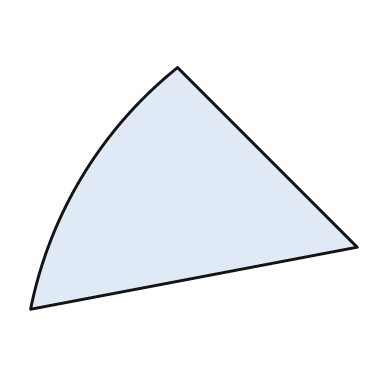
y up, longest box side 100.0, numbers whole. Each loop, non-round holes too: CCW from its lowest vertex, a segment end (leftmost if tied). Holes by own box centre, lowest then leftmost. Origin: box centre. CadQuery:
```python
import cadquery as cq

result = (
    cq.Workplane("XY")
    .moveTo(-50.0, -37.0)
    .lineTo(50.0, -18.0)
    .lineTo(-5.0, 37.0)
    .threePointArc((-34.0, 4.0), (-50.0, -37.0))
    .close()
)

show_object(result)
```